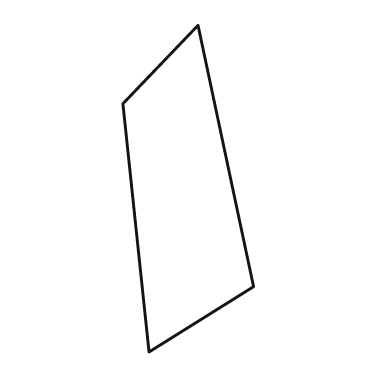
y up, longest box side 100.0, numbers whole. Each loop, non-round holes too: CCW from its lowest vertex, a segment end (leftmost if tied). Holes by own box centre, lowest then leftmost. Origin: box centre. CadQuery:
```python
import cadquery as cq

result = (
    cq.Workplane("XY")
    .moveTo(-12.0, -50.0)
    .lineTo(20.0, -30.0)
    .lineTo(3.0, 50.0)
    .lineTo(-20.0, 26.0)
    .close()
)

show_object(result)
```